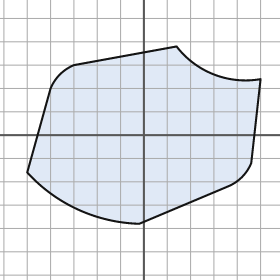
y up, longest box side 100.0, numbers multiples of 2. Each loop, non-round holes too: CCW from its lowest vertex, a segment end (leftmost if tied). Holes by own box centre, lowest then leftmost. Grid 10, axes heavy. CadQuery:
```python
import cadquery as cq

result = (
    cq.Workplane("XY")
    .moveTo(-2.0, -38.0)
    .lineTo(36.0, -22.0)
    .threePointArc((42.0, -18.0), (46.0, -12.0))
    .lineTo(50.0, 24.0)
    .threePointArc((30.0, 26.0), (14.0, 38.0))
    .lineTo(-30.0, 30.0)
    .threePointArc((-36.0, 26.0), (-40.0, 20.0))
    .lineTo(-50.0, -16.0)
    .threePointArc((-28.0, -32.0), (-2.0, -38.0))
    .close()
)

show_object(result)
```